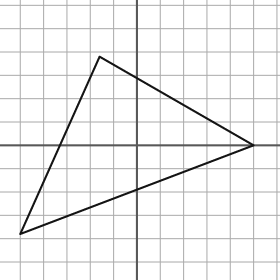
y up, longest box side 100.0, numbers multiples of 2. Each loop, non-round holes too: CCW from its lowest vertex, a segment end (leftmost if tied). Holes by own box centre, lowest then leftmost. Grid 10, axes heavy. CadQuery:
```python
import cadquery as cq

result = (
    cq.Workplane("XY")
    .moveTo(-50.0, -38.0)
    .lineTo(50.0, 0.0)
    .lineTo(-16.0, 38.0)
    .close()
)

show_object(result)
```